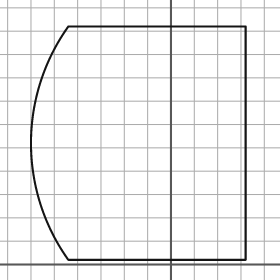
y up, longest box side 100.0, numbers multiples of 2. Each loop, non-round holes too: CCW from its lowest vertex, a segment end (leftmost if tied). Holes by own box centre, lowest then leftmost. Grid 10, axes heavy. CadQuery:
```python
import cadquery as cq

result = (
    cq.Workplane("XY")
    .moveTo(-44.0, 2.0)
    .lineTo(32.0, 2.0)
    .lineTo(32.0, 102.0)
    .lineTo(-44.0, 102.0)
    .threePointArc((-60.0, 52.0), (-44.0, 2.0))
    .close()
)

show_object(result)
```